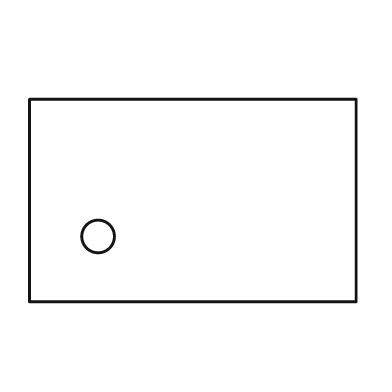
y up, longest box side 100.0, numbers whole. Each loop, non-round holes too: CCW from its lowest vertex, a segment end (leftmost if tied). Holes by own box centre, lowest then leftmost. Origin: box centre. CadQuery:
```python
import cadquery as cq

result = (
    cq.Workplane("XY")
    .moveTo(-50.0, -31.0)
    .lineTo(50.0, -31.0)
    .lineTo(50.0, 31.0)
    .lineTo(-50.0, 31.0)
    .close()
    .moveTo(-29.0, -11.0)
    .circle(5.0)
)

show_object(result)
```